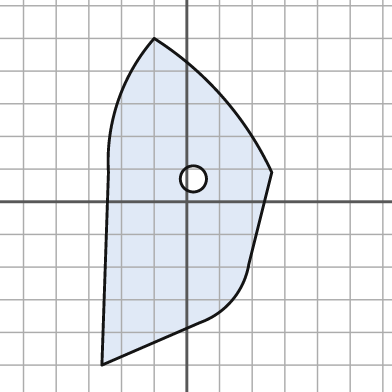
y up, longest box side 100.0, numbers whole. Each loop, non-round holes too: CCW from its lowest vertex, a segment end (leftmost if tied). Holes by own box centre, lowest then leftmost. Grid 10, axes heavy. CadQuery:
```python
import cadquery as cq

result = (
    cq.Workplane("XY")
    .moveTo(-26.0, -50.0)
    .lineTo(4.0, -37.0)
    .threePointArc((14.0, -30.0), (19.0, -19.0))
    .lineTo(26.0, 9.0)
    .threePointArc((11.0, 32.0), (-10.0, 50.0))
    .threePointArc((-21.0, 31.0), (-24.0, 9.0))
    .close()
    .moveTo(2.0, 7.0)
    .circle(4.0)
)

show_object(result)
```